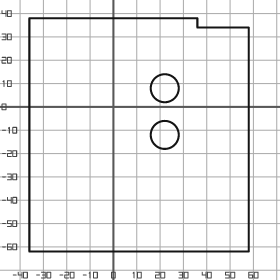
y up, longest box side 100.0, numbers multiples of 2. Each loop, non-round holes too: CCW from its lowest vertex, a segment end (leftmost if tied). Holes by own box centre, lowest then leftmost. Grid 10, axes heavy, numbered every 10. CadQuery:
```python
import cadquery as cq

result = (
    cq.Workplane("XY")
    .moveTo(-36.0, -62.0)
    .lineTo(58.0, -62.0)
    .lineTo(58.0, 34.0)
    .lineTo(36.0, 34.0)
    .lineTo(36.0, 38.0)
    .lineTo(-36.0, 38.0)
    .close()
    .moveTo(22.0, -12.0)
    .circle(6.0)
    .moveTo(22.0, 8.0)
    .circle(6.0)
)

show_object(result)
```